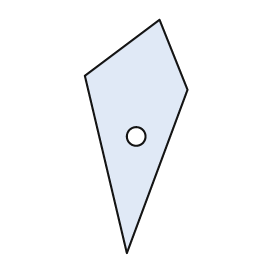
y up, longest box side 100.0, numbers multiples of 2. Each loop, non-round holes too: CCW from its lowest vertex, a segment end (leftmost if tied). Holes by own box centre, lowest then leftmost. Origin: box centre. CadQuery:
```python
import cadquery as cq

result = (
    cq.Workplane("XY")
    .moveTo(-4.0, -50.0)
    .lineTo(22.0, 20.0)
    .lineTo(10.0, 50.0)
    .lineTo(-22.0, 26.0)
    .close()
    .moveTo(0.0, 0.0)
    .circle(4.0)
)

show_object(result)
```